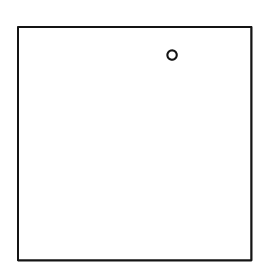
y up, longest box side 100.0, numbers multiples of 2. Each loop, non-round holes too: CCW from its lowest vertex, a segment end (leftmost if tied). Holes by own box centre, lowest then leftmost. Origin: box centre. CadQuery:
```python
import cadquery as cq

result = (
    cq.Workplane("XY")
    .moveTo(-50.0, -50.0)
    .lineTo(50.0, -50.0)
    .lineTo(50.0, 50.0)
    .lineTo(-50.0, 50.0)
    .close()
    .moveTo(16.0, 38.0)
    .circle(2.0)
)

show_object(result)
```